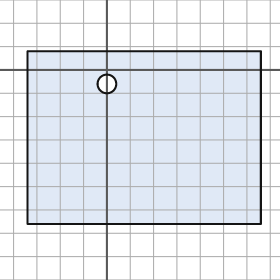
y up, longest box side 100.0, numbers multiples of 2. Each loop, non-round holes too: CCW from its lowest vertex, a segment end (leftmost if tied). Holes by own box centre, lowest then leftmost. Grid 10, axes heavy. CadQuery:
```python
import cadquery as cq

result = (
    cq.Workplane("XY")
    .moveTo(-34.0, -66.0)
    .lineTo(66.0, -66.0)
    .lineTo(66.0, 8.0)
    .lineTo(-34.0, 8.0)
    .close()
    .moveTo(0.0, -6.0)
    .circle(4.0)
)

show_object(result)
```